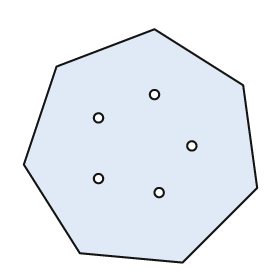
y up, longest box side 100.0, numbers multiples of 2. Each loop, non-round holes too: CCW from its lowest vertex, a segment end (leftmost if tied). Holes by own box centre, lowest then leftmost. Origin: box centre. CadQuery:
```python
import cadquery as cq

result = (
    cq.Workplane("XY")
    .moveTo(18.0, -50.0)
    .lineTo(50.0, -18.0)
    .lineTo(44.0, 26.0)
    .lineTo(6.0, 50.0)
    .lineTo(-36.0, 34.0)
    .lineTo(-50.0, -8.0)
    .lineTo(-26.0, -46.0)
    .close()
    .moveTo(8.0, -20.0)
    .circle(2.0)
    .moveTo(-18.0, -14.0)
    .circle(2.0)
    .moveTo(22.0, 0.0)
    .circle(2.0)
    .moveTo(-18.0, 12.0)
    .circle(2.0)
    .moveTo(6.0, 22.0)
    .circle(2.0)
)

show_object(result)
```